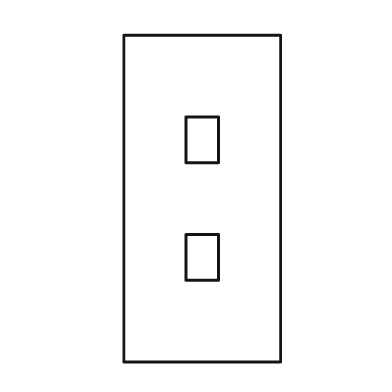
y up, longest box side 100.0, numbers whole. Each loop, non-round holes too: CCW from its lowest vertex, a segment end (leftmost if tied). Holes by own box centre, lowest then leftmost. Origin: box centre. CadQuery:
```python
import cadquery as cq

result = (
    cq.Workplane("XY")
    .moveTo(-24.0, -50.0)
    .lineTo(24.0, -50.0)
    .lineTo(24.0, 50.0)
    .lineTo(-24.0, 50.0)
    .close()
    .moveTo(-5.0, -25.0)
    .lineTo(5.0, -25.0)
    .lineTo(5.0, -11.0)
    .lineTo(-5.0, -11.0)
    .close()
    .moveTo(-5.0, 11.0)
    .lineTo(5.0, 11.0)
    .lineTo(5.0, 25.0)
    .lineTo(-5.0, 25.0)
    .close()
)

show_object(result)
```